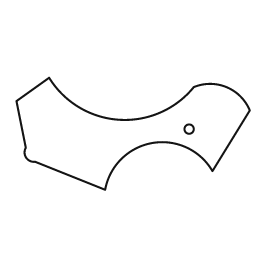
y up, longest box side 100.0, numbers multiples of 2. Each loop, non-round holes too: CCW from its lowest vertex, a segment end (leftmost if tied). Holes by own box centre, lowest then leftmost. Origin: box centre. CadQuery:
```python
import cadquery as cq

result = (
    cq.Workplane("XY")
    .moveTo(-12.0, -24.0)
    .threePointArc((8.0, -4.0), (34.0, -16.0))
    .lineTo(50.0, 10.0)
    .threePointArc((40.0, 20.0), (26.0, 20.0))
    .threePointArc((-6.0, 6.0), (-36.0, 24.0))
    .lineTo(-50.0, 14.0)
    .lineTo(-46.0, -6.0)
    .threePointArc((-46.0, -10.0), (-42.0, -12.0))
    .close()
    .moveTo(24.0, 2.0)
    .circle(2.0)
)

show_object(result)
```